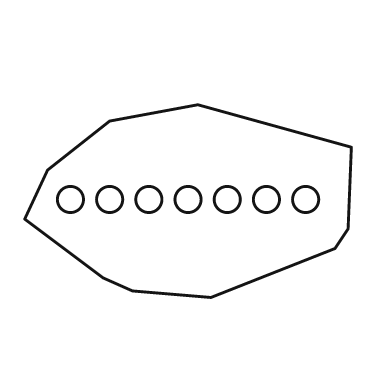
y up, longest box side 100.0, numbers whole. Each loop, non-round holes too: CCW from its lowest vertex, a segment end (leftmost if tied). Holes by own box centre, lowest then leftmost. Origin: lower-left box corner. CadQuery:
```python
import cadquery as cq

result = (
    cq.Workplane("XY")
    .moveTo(57.0, 0.0)
    .lineTo(95.0, 15.0)
    .lineTo(99.0, 21.0)
    .lineTo(100.0, 46.0)
    .lineTo(53.0, 59.0)
    .lineTo(26.0, 54.0)
    .lineTo(7.0, 39.0)
    .lineTo(0.0, 24.0)
    .lineTo(24.0, 6.0)
    .lineTo(33.0, 2.0)
    .close()
    .moveTo(14.0, 30.0)
    .circle(4.0)
    .moveTo(26.0, 30.0)
    .circle(4.0)
    .moveTo(38.0, 30.0)
    .circle(4.0)
    .moveTo(50.0, 30.0)
    .circle(4.0)
    .moveTo(62.0, 30.0)
    .circle(4.0)
    .moveTo(74.0, 30.0)
    .circle(4.0)
    .moveTo(86.0, 30.0)
    .circle(4.0)
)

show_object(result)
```